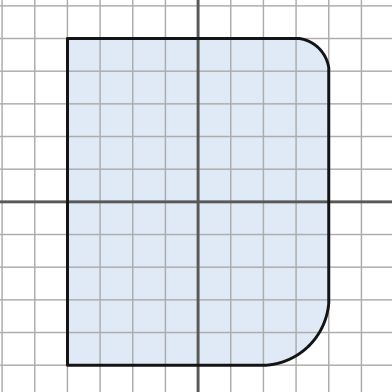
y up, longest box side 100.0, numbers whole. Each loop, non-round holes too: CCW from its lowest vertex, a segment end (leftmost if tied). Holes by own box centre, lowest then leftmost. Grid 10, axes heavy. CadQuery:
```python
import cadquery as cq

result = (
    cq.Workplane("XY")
    .moveTo(-40.0, -50.0)
    .lineTo(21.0, -50.0)
    .threePointArc((34.0, -44.0), (40.0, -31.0))
    .lineTo(40.0, 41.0)
    .threePointArc((37.0, 47.0), (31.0, 50.0))
    .lineTo(-40.0, 50.0)
    .close()
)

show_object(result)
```